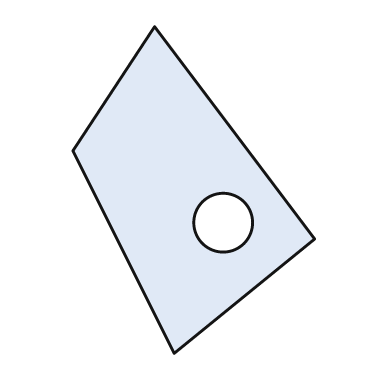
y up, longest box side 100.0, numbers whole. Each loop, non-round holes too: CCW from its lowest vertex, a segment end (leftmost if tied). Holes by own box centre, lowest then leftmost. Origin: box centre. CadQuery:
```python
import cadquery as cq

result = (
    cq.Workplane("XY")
    .moveTo(-6.0, -50.0)
    .lineTo(37.0, -15.0)
    .lineTo(-12.0, 50.0)
    .lineTo(-37.0, 12.0)
    .close()
    .moveTo(9.0, -10.0)
    .circle(9.0)
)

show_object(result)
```